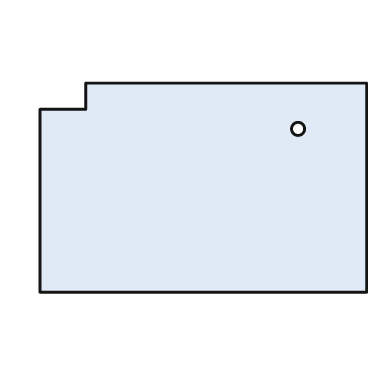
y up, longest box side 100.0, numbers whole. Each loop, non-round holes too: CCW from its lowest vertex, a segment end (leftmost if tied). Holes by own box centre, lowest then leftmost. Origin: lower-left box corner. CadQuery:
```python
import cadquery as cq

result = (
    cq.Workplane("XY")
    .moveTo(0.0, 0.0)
    .lineTo(100.0, 0.0)
    .lineTo(100.0, 64.0)
    .lineTo(14.0, 64.0)
    .lineTo(14.0, 56.0)
    .lineTo(0.0, 56.0)
    .close()
    .moveTo(79.0, 50.0)
    .circle(2.0)
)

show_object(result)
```